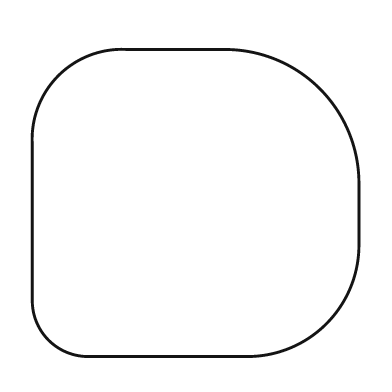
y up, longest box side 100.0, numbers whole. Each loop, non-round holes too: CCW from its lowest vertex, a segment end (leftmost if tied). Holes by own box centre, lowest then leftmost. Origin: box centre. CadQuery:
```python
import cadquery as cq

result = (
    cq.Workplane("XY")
    .moveTo(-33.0, -47.0)
    .lineTo(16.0, -47.0)
    .threePointArc((40.0, -37.0), (50.0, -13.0))
    .lineTo(50.0, 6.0)
    .threePointArc((38.0, 35.0), (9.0, 47.0))
    .lineTo(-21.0, 47.0)
    .threePointArc((-42.0, 39.0), (-50.0, 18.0))
    .lineTo(-50.0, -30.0)
    .threePointArc((-45.0, -42.0), (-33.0, -47.0))
    .close()
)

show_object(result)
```